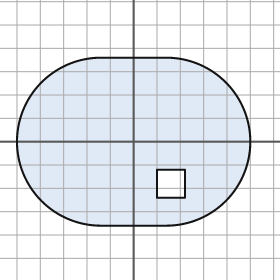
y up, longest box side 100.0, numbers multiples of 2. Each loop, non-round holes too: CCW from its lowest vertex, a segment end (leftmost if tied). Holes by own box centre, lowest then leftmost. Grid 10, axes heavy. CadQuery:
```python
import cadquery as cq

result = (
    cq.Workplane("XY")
    .moveTo(-14.0, -36.0)
    .lineTo(14.0, -36.0)
    .threePointArc((50.0, 0.0), (14.0, 36.0))
    .lineTo(-14.0, 36.0)
    .threePointArc((-50.0, 0.0), (-14.0, -36.0))
    .close()
    .moveTo(10.0, -24.0)
    .lineTo(22.0, -24.0)
    .lineTo(22.0, -12.0)
    .lineTo(10.0, -12.0)
    .close()
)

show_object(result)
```